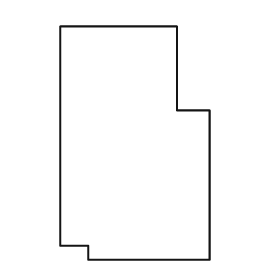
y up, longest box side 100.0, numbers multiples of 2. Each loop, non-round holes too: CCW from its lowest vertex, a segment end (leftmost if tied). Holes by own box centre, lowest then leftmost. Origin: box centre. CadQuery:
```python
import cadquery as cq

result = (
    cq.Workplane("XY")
    .moveTo(-20.0, -50.0)
    .lineTo(32.0, -50.0)
    .lineTo(32.0, 14.0)
    .lineTo(18.0, 14.0)
    .lineTo(18.0, 50.0)
    .lineTo(-32.0, 50.0)
    .lineTo(-32.0, -44.0)
    .lineTo(-20.0, -44.0)
    .close()
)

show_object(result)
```